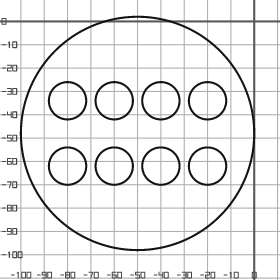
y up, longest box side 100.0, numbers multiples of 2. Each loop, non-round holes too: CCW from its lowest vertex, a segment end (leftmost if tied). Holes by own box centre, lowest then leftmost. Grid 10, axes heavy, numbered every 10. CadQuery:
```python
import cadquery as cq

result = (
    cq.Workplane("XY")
    .moveTo(-50.0, -48.0)
    .circle(50.0)
    .moveTo(-80.0, -62.0)
    .circle(8.0)
    .moveTo(-60.0, -62.0)
    .circle(8.0)
    .moveTo(-40.0, -62.0)
    .circle(8.0)
    .moveTo(-20.0, -62.0)
    .circle(8.0)
    .moveTo(-80.0, -34.0)
    .circle(8.0)
    .moveTo(-60.0, -34.0)
    .circle(8.0)
    .moveTo(-40.0, -34.0)
    .circle(8.0)
    .moveTo(-20.0, -34.0)
    .circle(8.0)
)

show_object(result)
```